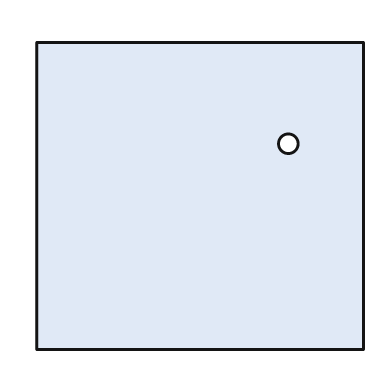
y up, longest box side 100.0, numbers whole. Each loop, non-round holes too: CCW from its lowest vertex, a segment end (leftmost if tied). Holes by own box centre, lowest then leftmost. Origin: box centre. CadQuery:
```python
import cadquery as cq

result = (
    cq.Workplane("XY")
    .moveTo(-50.0, -47.0)
    .lineTo(50.0, -47.0)
    .lineTo(50.0, 47.0)
    .lineTo(-50.0, 47.0)
    .close()
    .moveTo(27.0, 16.0)
    .circle(3.0)
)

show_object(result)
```